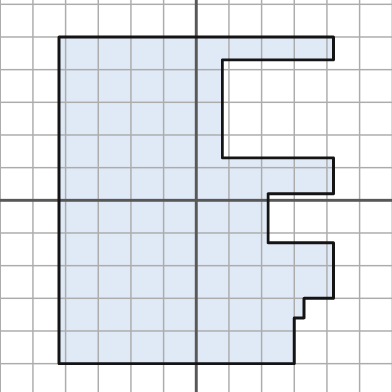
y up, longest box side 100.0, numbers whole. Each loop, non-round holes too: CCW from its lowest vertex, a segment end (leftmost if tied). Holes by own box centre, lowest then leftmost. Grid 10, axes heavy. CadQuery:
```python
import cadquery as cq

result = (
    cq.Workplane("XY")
    .moveTo(-42.0, -50.0)
    .lineTo(30.0, -50.0)
    .lineTo(30.0, -36.0)
    .lineTo(33.0, -36.0)
    .lineTo(33.0, -30.0)
    .lineTo(42.0, -30.0)
    .lineTo(42.0, -13.0)
    .lineTo(22.0, -13.0)
    .lineTo(22.0, 2.0)
    .lineTo(42.0, 2.0)
    .lineTo(42.0, 13.0)
    .lineTo(8.0, 13.0)
    .lineTo(8.0, 43.0)
    .lineTo(42.0, 43.0)
    .lineTo(42.0, 50.0)
    .lineTo(-42.0, 50.0)
    .close()
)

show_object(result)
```